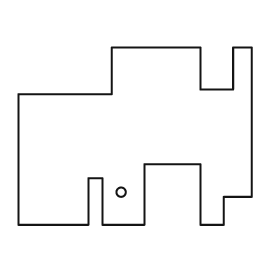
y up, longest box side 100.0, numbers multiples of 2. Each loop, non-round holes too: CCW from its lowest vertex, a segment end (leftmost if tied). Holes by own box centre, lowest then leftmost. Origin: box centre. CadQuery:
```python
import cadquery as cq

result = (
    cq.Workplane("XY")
    .moveTo(-50.0, -38.0)
    .lineTo(-20.0, -38.0)
    .lineTo(-20.0, -18.0)
    .lineTo(-14.0, -18.0)
    .lineTo(-14.0, -38.0)
    .lineTo(4.0, -38.0)
    .lineTo(4.0, -12.0)
    .lineTo(28.0, -12.0)
    .lineTo(28.0, -38.0)
    .lineTo(38.0, -38.0)
    .lineTo(38.0, -26.0)
    .lineTo(50.0, -26.0)
    .lineTo(50.0, 38.0)
    .lineTo(42.0, 38.0)
    .lineTo(42.0, 20.0)
    .lineTo(28.0, 20.0)
    .lineTo(28.0, 38.0)
    .lineTo(-10.0, 38.0)
    .lineTo(-10.0, 18.0)
    .lineTo(-50.0, 18.0)
    .close()
    .moveTo(-6.0, -24.0)
    .circle(2.0)
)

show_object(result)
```